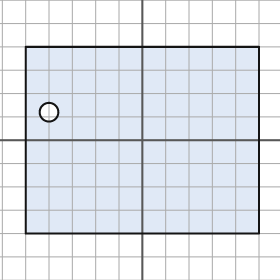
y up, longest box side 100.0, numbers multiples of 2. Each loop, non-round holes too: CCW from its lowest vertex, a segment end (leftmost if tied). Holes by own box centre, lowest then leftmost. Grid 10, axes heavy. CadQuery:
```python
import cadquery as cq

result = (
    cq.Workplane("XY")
    .moveTo(-50.0, -40.0)
    .lineTo(50.0, -40.0)
    .lineTo(50.0, 40.0)
    .lineTo(-50.0, 40.0)
    .close()
    .moveTo(-40.0, 12.0)
    .circle(4.0)
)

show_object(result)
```